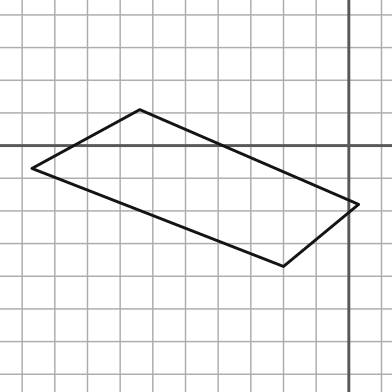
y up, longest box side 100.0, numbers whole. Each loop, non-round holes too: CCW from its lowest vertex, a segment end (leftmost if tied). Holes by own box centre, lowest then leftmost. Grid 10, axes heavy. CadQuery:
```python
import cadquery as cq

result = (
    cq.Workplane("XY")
    .moveTo(-20.0, -37.0)
    .lineTo(3.0, -18.0)
    .lineTo(-64.0, 11.0)
    .lineTo(-97.0, -7.0)
    .close()
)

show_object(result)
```